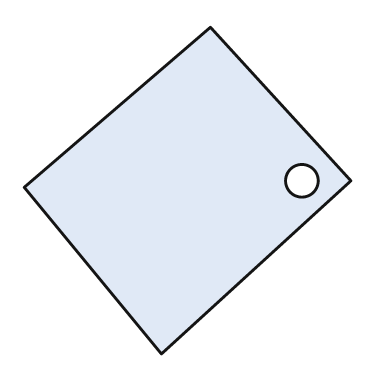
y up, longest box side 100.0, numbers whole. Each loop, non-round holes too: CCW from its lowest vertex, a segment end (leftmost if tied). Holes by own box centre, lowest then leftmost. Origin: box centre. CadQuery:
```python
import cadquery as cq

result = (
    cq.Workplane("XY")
    .moveTo(-8.0, -50.0)
    .lineTo(50.0, 3.0)
    .lineTo(7.0, 50.0)
    .lineTo(-50.0, 1.0)
    .close()
    .moveTo(35.0, 3.0)
    .circle(5.0)
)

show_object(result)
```